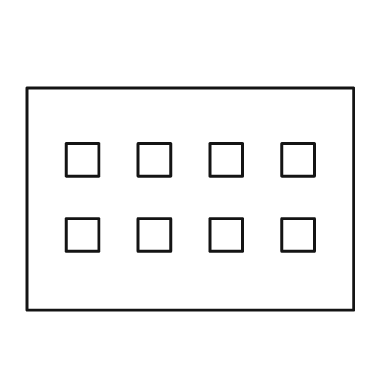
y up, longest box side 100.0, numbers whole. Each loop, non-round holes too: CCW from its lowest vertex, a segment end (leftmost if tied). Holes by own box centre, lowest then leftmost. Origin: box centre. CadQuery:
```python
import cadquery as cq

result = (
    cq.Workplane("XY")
    .moveTo(-50.0, -34.0)
    .lineTo(50.0, -34.0)
    .lineTo(50.0, 34.0)
    .lineTo(-50.0, 34.0)
    .close()
    .moveTo(-38.0, -16.0)
    .lineTo(-28.0, -16.0)
    .lineTo(-28.0, -6.0)
    .lineTo(-38.0, -6.0)
    .close()
    .moveTo(-16.0, -16.0)
    .lineTo(-6.0, -16.0)
    .lineTo(-6.0, -6.0)
    .lineTo(-16.0, -6.0)
    .close()
    .moveTo(6.0, -16.0)
    .lineTo(16.0, -16.0)
    .lineTo(16.0, -6.0)
    .lineTo(6.0, -6.0)
    .close()
    .moveTo(28.0, -16.0)
    .lineTo(38.0, -16.0)
    .lineTo(38.0, -6.0)
    .lineTo(28.0, -6.0)
    .close()
    .moveTo(-38.0, 7.0)
    .lineTo(-28.0, 7.0)
    .lineTo(-28.0, 17.0)
    .lineTo(-38.0, 17.0)
    .close()
    .moveTo(-16.0, 7.0)
    .lineTo(-6.0, 7.0)
    .lineTo(-6.0, 17.0)
    .lineTo(-16.0, 17.0)
    .close()
    .moveTo(6.0, 7.0)
    .lineTo(16.0, 7.0)
    .lineTo(16.0, 17.0)
    .lineTo(6.0, 17.0)
    .close()
    .moveTo(28.0, 7.0)
    .lineTo(38.0, 7.0)
    .lineTo(38.0, 17.0)
    .lineTo(28.0, 17.0)
    .close()
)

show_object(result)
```